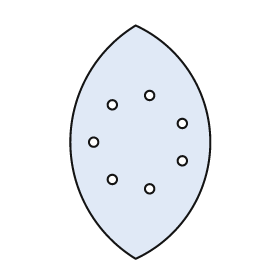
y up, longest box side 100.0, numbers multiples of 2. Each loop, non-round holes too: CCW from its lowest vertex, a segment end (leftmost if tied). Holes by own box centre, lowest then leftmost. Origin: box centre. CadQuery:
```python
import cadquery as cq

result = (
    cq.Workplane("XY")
    .moveTo(-2.0, -50.0)
    .threePointArc((30.0, 0.0), (-2.0, 50.0))
    .threePointArc((-30.0, 0.0), (-2.0, -50.0))
    .close()
    .moveTo(4.0, -20.0)
    .circle(2.0)
    .moveTo(-12.0, -16.0)
    .circle(2.0)
    .moveTo(18.0, -8.0)
    .circle(2.0)
    .moveTo(-20.0, 0.0)
    .circle(2.0)
    .moveTo(18.0, 8.0)
    .circle(2.0)
    .moveTo(-12.0, 16.0)
    .circle(2.0)
    .moveTo(4.0, 20.0)
    .circle(2.0)
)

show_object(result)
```